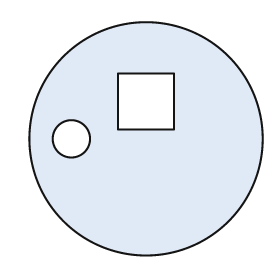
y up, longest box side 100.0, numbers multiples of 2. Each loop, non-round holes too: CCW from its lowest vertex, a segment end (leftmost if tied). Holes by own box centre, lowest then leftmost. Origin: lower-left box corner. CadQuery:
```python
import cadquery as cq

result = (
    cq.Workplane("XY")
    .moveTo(50.0, 50.0)
    .circle(50.0)
    .moveTo(18.0, 50.0)
    .circle(8.0)
    .moveTo(38.0, 54.0)
    .lineTo(62.0, 54.0)
    .lineTo(62.0, 78.0)
    .lineTo(38.0, 78.0)
    .close()
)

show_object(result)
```